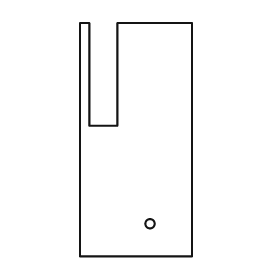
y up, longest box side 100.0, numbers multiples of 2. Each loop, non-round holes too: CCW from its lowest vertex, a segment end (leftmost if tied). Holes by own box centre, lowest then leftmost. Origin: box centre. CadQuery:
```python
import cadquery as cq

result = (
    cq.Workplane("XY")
    .moveTo(-24.0, -50.0)
    .lineTo(24.0, -50.0)
    .lineTo(24.0, 50.0)
    .lineTo(-8.0, 50.0)
    .lineTo(-8.0, 6.0)
    .lineTo(-20.0, 6.0)
    .lineTo(-20.0, 50.0)
    .lineTo(-24.0, 50.0)
    .close()
    .moveTo(6.0, -36.0)
    .circle(2.0)
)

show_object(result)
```